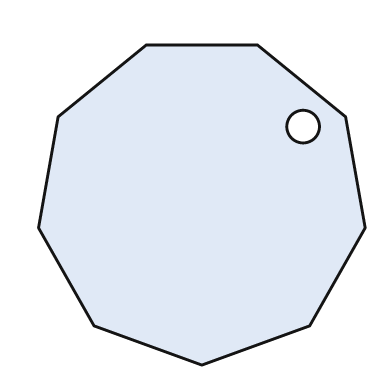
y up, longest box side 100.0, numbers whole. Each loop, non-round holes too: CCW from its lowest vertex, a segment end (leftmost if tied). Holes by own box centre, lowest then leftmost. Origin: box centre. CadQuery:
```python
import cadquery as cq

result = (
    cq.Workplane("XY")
    .moveTo(0.0, -49.0)
    .lineTo(33.0, -37.0)
    .lineTo(50.0, -7.0)
    .lineTo(44.0, 27.0)
    .lineTo(17.0, 49.0)
    .lineTo(-17.0, 49.0)
    .lineTo(-44.0, 27.0)
    .lineTo(-50.0, -7.0)
    .lineTo(-33.0, -37.0)
    .close()
    .moveTo(31.0, 24.0)
    .circle(5.0)
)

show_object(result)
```